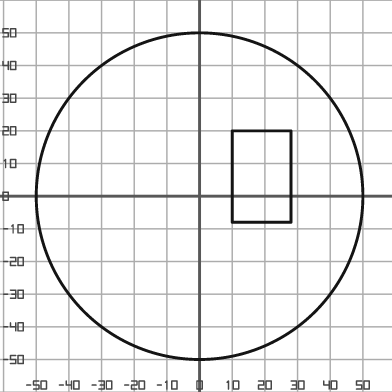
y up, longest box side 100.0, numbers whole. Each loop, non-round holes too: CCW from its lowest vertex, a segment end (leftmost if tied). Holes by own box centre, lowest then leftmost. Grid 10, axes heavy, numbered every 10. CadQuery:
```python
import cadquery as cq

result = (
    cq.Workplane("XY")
    .moveTo(0.0, 0.0)
    .circle(50.0)
    .moveTo(10.0, -8.0)
    .lineTo(28.0, -8.0)
    .lineTo(28.0, 20.0)
    .lineTo(10.0, 20.0)
    .close()
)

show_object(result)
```